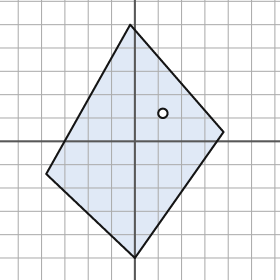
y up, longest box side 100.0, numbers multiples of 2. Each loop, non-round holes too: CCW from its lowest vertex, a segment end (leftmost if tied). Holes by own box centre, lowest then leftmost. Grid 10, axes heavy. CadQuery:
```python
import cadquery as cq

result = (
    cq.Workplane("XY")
    .moveTo(0.0, -50.0)
    .lineTo(38.0, 4.0)
    .lineTo(-2.0, 50.0)
    .lineTo(-38.0, -14.0)
    .close()
    .moveTo(12.0, 12.0)
    .circle(2.0)
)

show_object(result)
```